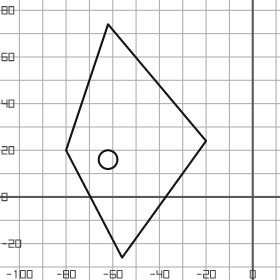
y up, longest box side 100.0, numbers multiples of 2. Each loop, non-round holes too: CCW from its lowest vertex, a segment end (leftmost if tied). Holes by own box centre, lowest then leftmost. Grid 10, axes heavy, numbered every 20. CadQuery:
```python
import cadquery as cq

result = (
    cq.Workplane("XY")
    .moveTo(-56.0, -26.0)
    .lineTo(-20.0, 24.0)
    .lineTo(-62.0, 74.0)
    .lineTo(-80.0, 20.0)
    .close()
    .moveTo(-62.0, 16.0)
    .circle(4.0)
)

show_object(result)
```